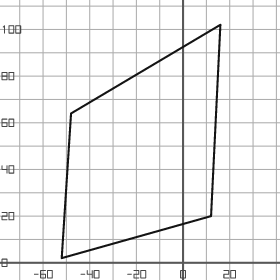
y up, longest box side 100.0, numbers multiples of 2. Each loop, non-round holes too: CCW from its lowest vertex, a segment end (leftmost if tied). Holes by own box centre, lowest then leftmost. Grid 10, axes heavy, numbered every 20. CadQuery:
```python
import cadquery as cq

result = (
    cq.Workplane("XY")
    .moveTo(-52.0, 2.0)
    .lineTo(12.0, 20.0)
    .lineTo(16.0, 102.0)
    .lineTo(-48.0, 64.0)
    .close()
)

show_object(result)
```